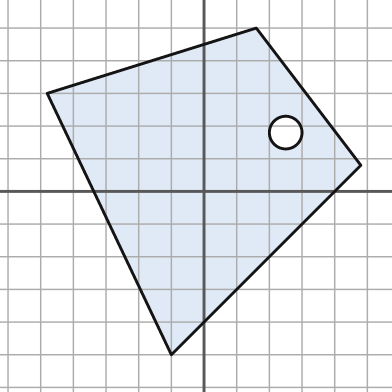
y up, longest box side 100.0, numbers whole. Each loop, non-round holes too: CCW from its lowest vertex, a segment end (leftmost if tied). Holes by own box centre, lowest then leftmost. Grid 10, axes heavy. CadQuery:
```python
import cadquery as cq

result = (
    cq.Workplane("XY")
    .moveTo(-10.0, -50.0)
    .lineTo(48.0, 8.0)
    .lineTo(16.0, 50.0)
    .lineTo(-48.0, 30.0)
    .close()
    .moveTo(25.0, 18.0)
    .circle(5.0)
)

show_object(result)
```